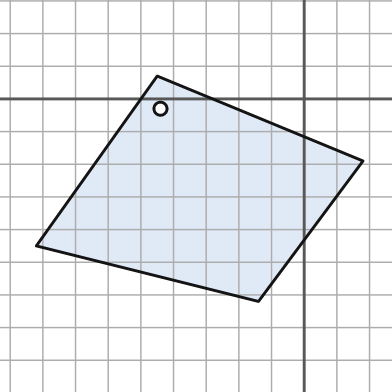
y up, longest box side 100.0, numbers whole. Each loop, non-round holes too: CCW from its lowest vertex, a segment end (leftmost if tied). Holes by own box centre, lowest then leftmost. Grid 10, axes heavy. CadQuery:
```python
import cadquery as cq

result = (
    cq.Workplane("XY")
    .moveTo(-14.0, -62.0)
    .lineTo(18.0, -19.0)
    .lineTo(-45.0, 7.0)
    .lineTo(-82.0, -45.0)
    .close()
    .moveTo(-44.0, -3.0)
    .circle(2.0)
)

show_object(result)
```